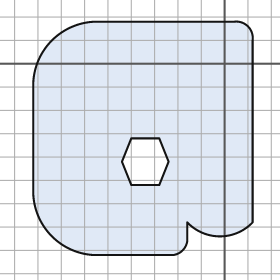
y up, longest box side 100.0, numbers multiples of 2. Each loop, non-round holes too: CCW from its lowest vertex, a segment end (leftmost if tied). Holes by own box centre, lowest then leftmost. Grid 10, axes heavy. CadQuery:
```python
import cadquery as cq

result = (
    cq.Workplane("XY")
    .moveTo(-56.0, -82.0)
    .lineTo(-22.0, -82.0)
    .threePointArc((-18.0, -80.0), (-16.0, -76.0))
    .lineTo(-16.0, -68.0)
    .threePointArc((-2.0, -74.0), (12.0, -68.0))
    .lineTo(12.0, 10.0)
    .threePointArc((10.0, 16.0), (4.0, 18.0))
    .lineTo(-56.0, 18.0)
    .threePointArc((-74.0, 10.0), (-82.0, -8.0))
    .lineTo(-82.0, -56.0)
    .threePointArc((-74.0, -74.0), (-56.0, -82.0))
    .close()
    .moveTo(-40.0, -52.0)
    .lineTo(-28.0, -52.0)
    .lineTo(-24.0, -42.0)
    .lineTo(-28.0, -32.0)
    .lineTo(-40.0, -32.0)
    .lineTo(-44.0, -42.0)
    .close()
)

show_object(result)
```